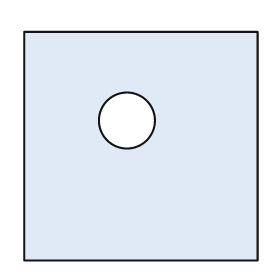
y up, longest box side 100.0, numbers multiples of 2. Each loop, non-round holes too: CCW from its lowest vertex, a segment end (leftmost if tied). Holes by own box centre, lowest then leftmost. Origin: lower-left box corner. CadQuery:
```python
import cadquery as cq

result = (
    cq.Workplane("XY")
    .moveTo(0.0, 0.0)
    .lineTo(100.0, 0.0)
    .lineTo(100.0, 98.0)
    .lineTo(0.0, 98.0)
    .close()
    .moveTo(44.0, 60.0)
    .circle(12.0)
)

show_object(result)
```